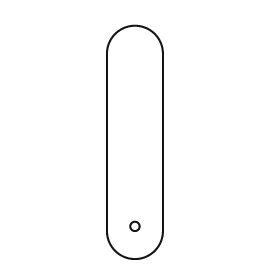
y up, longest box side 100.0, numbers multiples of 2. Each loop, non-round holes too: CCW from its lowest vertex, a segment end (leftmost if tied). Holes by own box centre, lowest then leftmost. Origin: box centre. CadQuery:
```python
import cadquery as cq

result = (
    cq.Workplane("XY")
    .moveTo(-12.0, -38.0)
    .threePointArc((0.0, -50.0), (12.0, -38.0))
    .lineTo(12.0, 38.0)
    .threePointArc((0.0, 50.0), (-12.0, 38.0))
    .close()
    .moveTo(0.0, -36.0)
    .circle(2.0)
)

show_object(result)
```